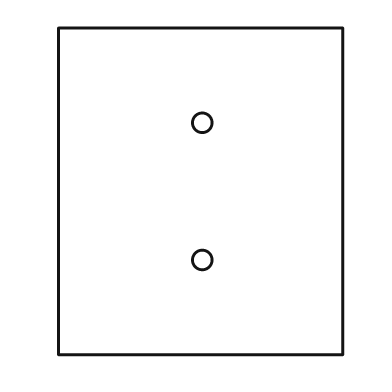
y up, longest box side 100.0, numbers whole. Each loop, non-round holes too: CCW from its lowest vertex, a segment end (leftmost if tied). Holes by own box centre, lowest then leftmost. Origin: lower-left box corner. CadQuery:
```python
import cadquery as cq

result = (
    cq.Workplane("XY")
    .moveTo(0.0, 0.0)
    .lineTo(87.0, 0.0)
    .lineTo(87.0, 100.0)
    .lineTo(0.0, 100.0)
    .close()
    .moveTo(44.0, 29.0)
    .circle(3.0)
    .moveTo(44.0, 71.0)
    .circle(3.0)
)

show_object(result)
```